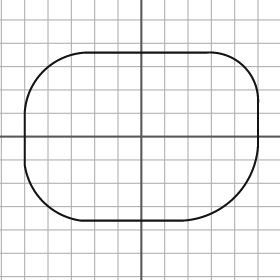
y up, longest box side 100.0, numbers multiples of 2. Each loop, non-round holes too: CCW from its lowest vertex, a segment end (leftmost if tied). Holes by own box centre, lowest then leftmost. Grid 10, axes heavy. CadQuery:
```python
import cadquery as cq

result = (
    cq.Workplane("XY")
    .moveTo(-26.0, -36.0)
    .lineTo(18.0, -36.0)
    .threePointArc((40.0, -26.0), (50.0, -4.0))
    .lineTo(50.0, 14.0)
    .threePointArc((44.0, 30.0), (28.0, 36.0))
    .lineTo(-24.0, 36.0)
    .threePointArc((-42.0, 28.0), (-50.0, 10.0))
    .lineTo(-50.0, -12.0)
    .threePointArc((-42.0, -28.0), (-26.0, -36.0))
    .close()
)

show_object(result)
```